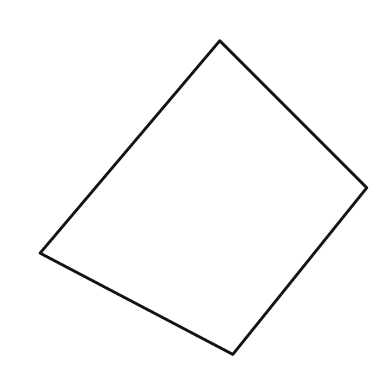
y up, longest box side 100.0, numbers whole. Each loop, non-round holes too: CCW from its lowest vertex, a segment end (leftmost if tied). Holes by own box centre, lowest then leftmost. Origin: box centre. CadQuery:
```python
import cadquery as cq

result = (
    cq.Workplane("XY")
    .moveTo(9.0, -48.0)
    .lineTo(50.0, 3.0)
    .lineTo(5.0, 48.0)
    .lineTo(-50.0, -17.0)
    .close()
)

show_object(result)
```